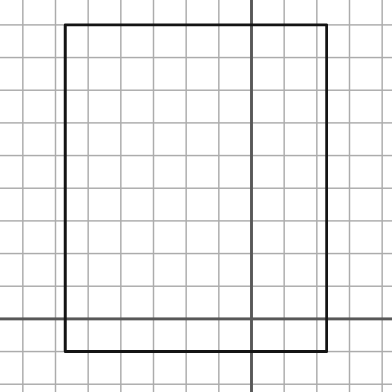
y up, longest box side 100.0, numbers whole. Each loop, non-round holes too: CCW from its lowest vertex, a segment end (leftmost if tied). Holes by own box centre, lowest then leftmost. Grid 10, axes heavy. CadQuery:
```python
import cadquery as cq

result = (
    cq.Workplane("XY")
    .moveTo(-57.0, -10.0)
    .lineTo(23.0, -10.0)
    .lineTo(23.0, 90.0)
    .lineTo(-57.0, 90.0)
    .close()
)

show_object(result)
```